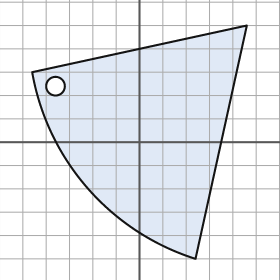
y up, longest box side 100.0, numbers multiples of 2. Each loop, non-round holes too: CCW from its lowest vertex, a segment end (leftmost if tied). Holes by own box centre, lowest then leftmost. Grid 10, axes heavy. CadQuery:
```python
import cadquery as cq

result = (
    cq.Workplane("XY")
    .moveTo(24.0, -50.0)
    .lineTo(46.0, 50.0)
    .lineTo(-46.0, 30.0)
    .threePointArc((-22.0, -20.0), (24.0, -50.0))
    .close()
    .moveTo(-36.0, 24.0)
    .circle(4.0)
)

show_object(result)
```